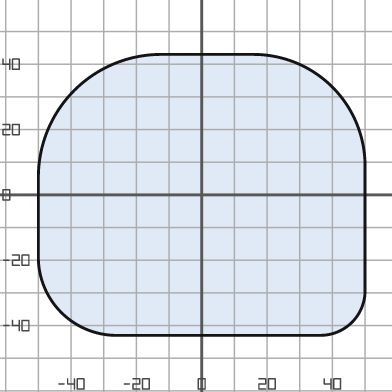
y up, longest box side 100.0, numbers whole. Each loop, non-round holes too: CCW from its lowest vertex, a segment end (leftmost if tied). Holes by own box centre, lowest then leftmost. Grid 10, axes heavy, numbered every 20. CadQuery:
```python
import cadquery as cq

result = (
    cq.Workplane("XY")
    .moveTo(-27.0, -43.0)
    .lineTo(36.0, -43.0)
    .threePointArc((46.0, -39.0), (50.0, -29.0))
    .lineTo(50.0, 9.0)
    .threePointArc((40.0, 33.0), (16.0, 43.0))
    .lineTo(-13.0, 43.0)
    .threePointArc((-39.0, 32.0), (-50.0, 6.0))
    .lineTo(-50.0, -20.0)
    .threePointArc((-43.0, -36.0), (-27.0, -43.0))
    .close()
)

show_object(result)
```